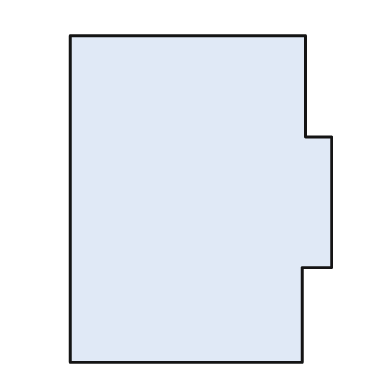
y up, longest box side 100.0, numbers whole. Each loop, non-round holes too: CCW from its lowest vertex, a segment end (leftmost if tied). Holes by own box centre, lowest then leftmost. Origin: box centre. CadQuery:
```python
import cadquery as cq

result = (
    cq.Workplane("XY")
    .moveTo(-40.0, -50.0)
    .lineTo(31.0, -50.0)
    .lineTo(31.0, -21.0)
    .lineTo(40.0, -21.0)
    .lineTo(40.0, 19.0)
    .lineTo(32.0, 19.0)
    .lineTo(32.0, 50.0)
    .lineTo(-40.0, 50.0)
    .close()
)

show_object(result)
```